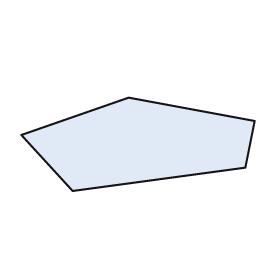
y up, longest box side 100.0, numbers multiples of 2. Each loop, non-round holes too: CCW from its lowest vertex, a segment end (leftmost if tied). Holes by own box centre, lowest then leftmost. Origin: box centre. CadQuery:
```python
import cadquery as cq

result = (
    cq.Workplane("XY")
    .moveTo(-28.0, -20.0)
    .lineTo(46.0, -10.0)
    .lineTo(50.0, 10.0)
    .lineTo(-4.0, 20.0)
    .lineTo(-50.0, 4.0)
    .close()
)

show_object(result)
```